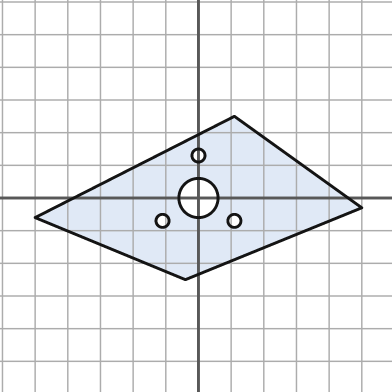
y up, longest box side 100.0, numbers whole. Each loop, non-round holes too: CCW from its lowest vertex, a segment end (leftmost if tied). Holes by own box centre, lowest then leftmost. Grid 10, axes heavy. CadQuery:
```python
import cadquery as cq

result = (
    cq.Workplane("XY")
    .moveTo(-4.0, -25.0)
    .lineTo(50.0, -3.0)
    .lineTo(11.0, 25.0)
    .lineTo(-50.0, -6.0)
    .close()
    .moveTo(-11.0, -7.0)
    .circle(2.0)
    .moveTo(11.0, -7.0)
    .circle(2.0)
    .moveTo(0.0, 0.0)
    .circle(6.0)
    .moveTo(0.0, 13.0)
    .circle(2.0)
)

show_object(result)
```